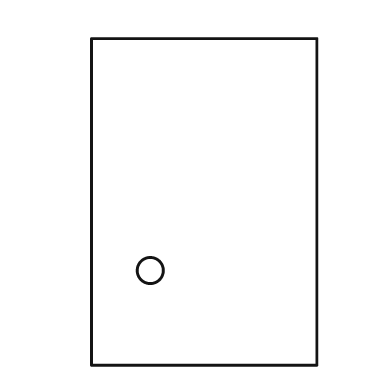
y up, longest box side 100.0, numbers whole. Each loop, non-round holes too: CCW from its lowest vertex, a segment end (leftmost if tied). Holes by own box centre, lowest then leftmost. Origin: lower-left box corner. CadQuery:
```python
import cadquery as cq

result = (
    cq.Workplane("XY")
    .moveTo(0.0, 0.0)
    .lineTo(69.0, 0.0)
    .lineTo(69.0, 100.0)
    .lineTo(0.0, 100.0)
    .close()
    .moveTo(18.0, 29.0)
    .circle(4.0)
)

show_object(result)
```